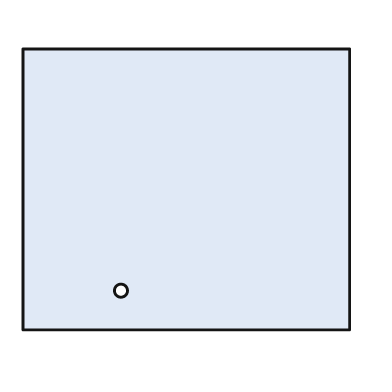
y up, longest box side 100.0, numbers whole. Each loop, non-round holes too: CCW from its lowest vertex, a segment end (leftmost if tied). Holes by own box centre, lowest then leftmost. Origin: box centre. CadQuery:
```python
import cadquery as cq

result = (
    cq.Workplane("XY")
    .moveTo(-50.0, -43.0)
    .lineTo(50.0, -43.0)
    .lineTo(50.0, 43.0)
    .lineTo(-50.0, 43.0)
    .close()
    .moveTo(-20.0, -31.0)
    .circle(2.0)
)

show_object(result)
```